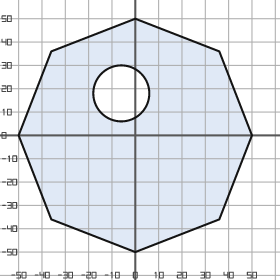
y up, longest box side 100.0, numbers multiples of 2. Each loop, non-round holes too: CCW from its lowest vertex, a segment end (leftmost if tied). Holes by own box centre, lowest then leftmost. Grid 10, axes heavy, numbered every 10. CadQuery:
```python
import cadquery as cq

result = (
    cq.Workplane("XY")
    .moveTo(0.0, -50.0)
    .lineTo(36.0, -36.0)
    .lineTo(50.0, 0.0)
    .lineTo(36.0, 36.0)
    .lineTo(0.0, 50.0)
    .lineTo(-36.0, 36.0)
    .lineTo(-50.0, 0.0)
    .lineTo(-36.0, -36.0)
    .close()
    .moveTo(-6.0, 18.0)
    .circle(12.0)
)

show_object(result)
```